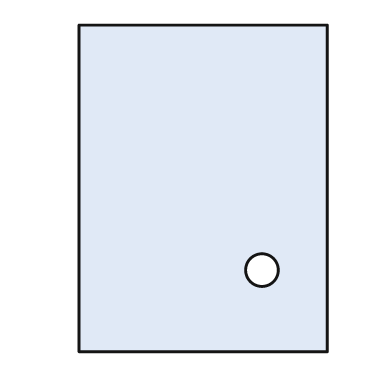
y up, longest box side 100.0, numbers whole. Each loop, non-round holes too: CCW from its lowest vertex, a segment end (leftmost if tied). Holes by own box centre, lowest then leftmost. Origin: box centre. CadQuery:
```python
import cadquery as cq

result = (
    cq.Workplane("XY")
    .moveTo(-38.0, -50.0)
    .lineTo(38.0, -50.0)
    .lineTo(38.0, 50.0)
    .lineTo(-38.0, 50.0)
    .close()
    .moveTo(18.0, -25.0)
    .circle(5.0)
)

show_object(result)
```